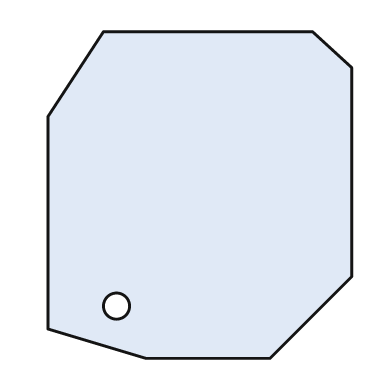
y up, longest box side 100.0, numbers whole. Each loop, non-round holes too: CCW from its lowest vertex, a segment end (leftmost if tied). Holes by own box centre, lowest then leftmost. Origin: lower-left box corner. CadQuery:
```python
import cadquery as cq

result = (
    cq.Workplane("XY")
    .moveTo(30.0, 0.0)
    .lineTo(68.0, 0.0)
    .lineTo(93.0, 25.0)
    .lineTo(93.0, 89.0)
    .lineTo(81.0, 100.0)
    .lineTo(17.0, 100.0)
    .lineTo(0.0, 74.0)
    .lineTo(0.0, 9.0)
    .close()
    .moveTo(21.0, 16.0)
    .circle(4.0)
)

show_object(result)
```